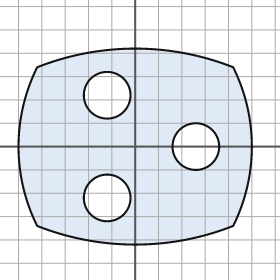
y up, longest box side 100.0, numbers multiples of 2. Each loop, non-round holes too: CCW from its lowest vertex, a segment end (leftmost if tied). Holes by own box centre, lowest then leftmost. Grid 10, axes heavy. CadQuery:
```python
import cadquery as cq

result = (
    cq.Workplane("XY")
    .moveTo(-42.0, -34.0)
    .threePointArc((0.0, -42.0), (42.0, -34.0))
    .threePointArc((50.0, 0.0), (42.0, 34.0))
    .threePointArc((0.0, 42.0), (-42.0, 34.0))
    .threePointArc((-50.0, 0.0), (-42.0, -34.0))
    .close()
    .moveTo(-12.0, -22.0)
    .circle(10.0)
    .moveTo(26.0, 0.0)
    .circle(10.0)
    .moveTo(-12.0, 22.0)
    .circle(10.0)
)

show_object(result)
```